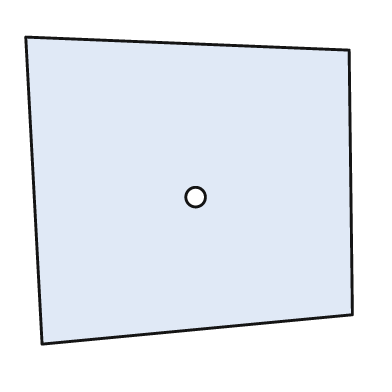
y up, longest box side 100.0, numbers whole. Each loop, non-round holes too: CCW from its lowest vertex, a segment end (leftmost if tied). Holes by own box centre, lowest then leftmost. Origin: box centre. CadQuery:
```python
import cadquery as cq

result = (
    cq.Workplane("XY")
    .moveTo(-45.0, -47.0)
    .lineTo(50.0, -38.0)
    .lineTo(49.0, 43.0)
    .lineTo(-50.0, 47.0)
    .close()
    .moveTo(2.0, -2.0)
    .circle(3.0)
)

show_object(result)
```